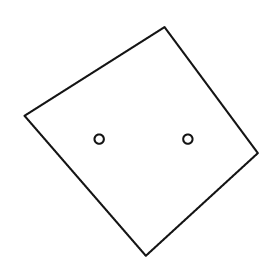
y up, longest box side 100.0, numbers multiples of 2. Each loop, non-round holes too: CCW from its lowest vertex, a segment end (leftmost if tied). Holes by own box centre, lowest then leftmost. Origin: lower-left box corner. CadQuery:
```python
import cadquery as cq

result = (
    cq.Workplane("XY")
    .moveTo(52.0, 0.0)
    .lineTo(100.0, 44.0)
    .lineTo(60.0, 98.0)
    .lineTo(0.0, 60.0)
    .close()
    .moveTo(32.0, 50.0)
    .circle(2.0)
    .moveTo(70.0, 50.0)
    .circle(2.0)
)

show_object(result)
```